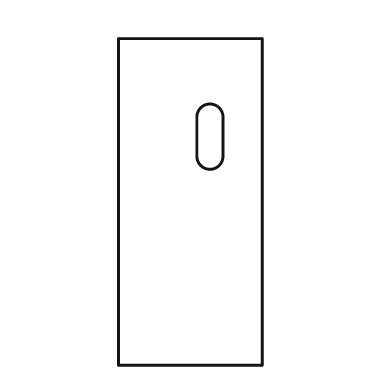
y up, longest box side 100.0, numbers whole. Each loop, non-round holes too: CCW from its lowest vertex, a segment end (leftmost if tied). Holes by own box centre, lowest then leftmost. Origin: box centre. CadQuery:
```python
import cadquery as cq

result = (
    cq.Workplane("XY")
    .moveTo(-22.0, -50.0)
    .lineTo(22.0, -50.0)
    .lineTo(22.0, 50.0)
    .lineTo(-22.0, 50.0)
    .close()
    .moveTo(2.0, 14.0)
    .threePointArc((6.0, 10.0), (10.0, 14.0))
    .lineTo(10.0, 26.0)
    .threePointArc((6.0, 30.0), (2.0, 26.0))
    .close()
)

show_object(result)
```